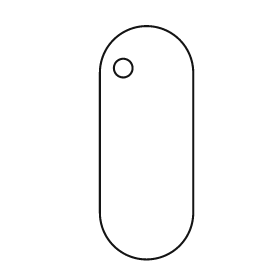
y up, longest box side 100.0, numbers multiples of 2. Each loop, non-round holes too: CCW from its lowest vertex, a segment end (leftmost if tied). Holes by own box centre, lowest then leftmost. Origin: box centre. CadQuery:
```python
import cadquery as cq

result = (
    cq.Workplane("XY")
    .moveTo(-20.0, -30.0)
    .threePointArc((0.0, -50.0), (20.0, -30.0))
    .lineTo(20.0, 30.0)
    .threePointArc((0.0, 50.0), (-20.0, 30.0))
    .close()
    .moveTo(-10.0, 32.0)
    .circle(4.0)
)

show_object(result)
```